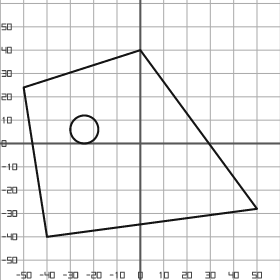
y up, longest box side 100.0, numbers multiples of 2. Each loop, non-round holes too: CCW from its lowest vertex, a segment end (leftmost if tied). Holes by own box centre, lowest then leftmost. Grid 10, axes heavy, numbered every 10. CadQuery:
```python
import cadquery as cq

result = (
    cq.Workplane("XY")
    .moveTo(-40.0, -40.0)
    .lineTo(50.0, -28.0)
    .lineTo(0.0, 40.0)
    .lineTo(-50.0, 24.0)
    .close()
    .moveTo(-24.0, 6.0)
    .circle(6.0)
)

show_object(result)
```